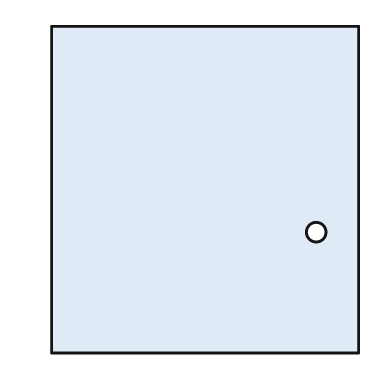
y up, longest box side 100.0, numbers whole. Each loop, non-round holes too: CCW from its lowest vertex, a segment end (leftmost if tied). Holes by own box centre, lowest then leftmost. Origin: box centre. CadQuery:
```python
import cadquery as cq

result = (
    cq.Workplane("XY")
    .moveTo(-47.0, -50.0)
    .lineTo(47.0, -50.0)
    .lineTo(47.0, 50.0)
    .lineTo(-47.0, 50.0)
    .close()
    .moveTo(34.0, -13.0)
    .circle(3.0)
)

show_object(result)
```